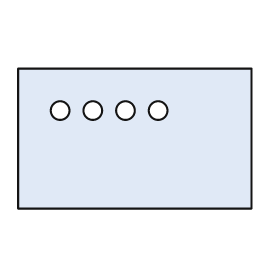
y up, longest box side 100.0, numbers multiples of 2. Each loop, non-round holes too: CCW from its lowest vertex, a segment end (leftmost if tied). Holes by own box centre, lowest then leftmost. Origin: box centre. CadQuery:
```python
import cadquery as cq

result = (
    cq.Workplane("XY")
    .moveTo(-50.0, -30.0)
    .lineTo(50.0, -30.0)
    .lineTo(50.0, 30.0)
    .lineTo(-50.0, 30.0)
    .close()
    .moveTo(-32.0, 12.0)
    .circle(4.0)
    .moveTo(-18.0, 12.0)
    .circle(4.0)
    .moveTo(-4.0, 12.0)
    .circle(4.0)
    .moveTo(10.0, 12.0)
    .circle(4.0)
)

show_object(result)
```